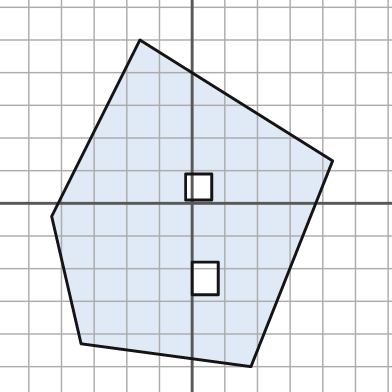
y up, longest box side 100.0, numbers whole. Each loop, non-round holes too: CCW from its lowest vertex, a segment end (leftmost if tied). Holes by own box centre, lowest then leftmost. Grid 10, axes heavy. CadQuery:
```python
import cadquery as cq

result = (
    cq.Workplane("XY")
    .moveTo(18.0, -50.0)
    .lineTo(43.0, 13.0)
    .lineTo(-16.0, 50.0)
    .lineTo(-43.0, -4.0)
    .lineTo(-34.0, -43.0)
    .close()
    .moveTo(0.0, -28.0)
    .lineTo(8.0, -28.0)
    .lineTo(8.0, -18.0)
    .lineTo(0.0, -18.0)
    .close()
    .moveTo(-2.0, 1.0)
    .lineTo(6.0, 1.0)
    .lineTo(6.0, 9.0)
    .lineTo(-2.0, 9.0)
    .close()
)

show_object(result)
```